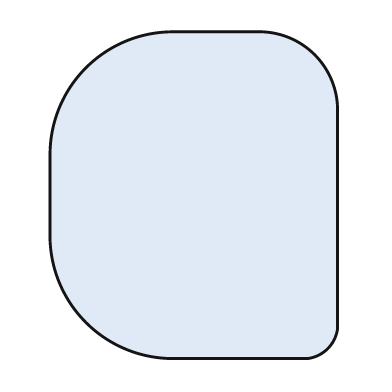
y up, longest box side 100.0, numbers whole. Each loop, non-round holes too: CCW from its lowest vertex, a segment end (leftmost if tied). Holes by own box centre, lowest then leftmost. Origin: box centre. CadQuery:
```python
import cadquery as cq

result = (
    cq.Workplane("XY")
    .moveTo(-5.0, -50.0)
    .lineTo(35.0, -50.0)
    .threePointArc((41.0, -47.0), (44.0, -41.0))
    .lineTo(44.0, 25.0)
    .threePointArc((37.0, 43.0), (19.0, 50.0))
    .lineTo(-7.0, 50.0)
    .threePointArc((-33.0, 39.0), (-44.0, 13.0))
    .lineTo(-44.0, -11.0)
    .threePointArc((-33.0, -39.0), (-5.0, -50.0))
    .close()
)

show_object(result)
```